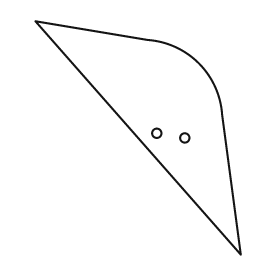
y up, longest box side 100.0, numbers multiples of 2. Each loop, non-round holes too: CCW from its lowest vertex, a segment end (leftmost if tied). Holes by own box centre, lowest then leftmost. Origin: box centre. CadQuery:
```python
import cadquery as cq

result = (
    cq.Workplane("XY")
    .moveTo(44.0, -50.0)
    .lineTo(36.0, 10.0)
    .threePointArc((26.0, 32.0), (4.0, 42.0))
    .lineTo(-44.0, 50.0)
    .close()
    .moveTo(20.0, 0.0)
    .circle(2.0)
    .moveTo(8.0, 2.0)
    .circle(2.0)
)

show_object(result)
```